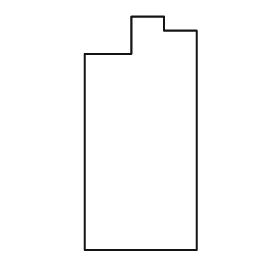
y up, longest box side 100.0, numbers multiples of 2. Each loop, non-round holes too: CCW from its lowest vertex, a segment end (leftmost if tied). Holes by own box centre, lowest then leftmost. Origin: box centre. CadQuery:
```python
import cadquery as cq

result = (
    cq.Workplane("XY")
    .moveTo(-24.0, -50.0)
    .lineTo(24.0, -50.0)
    .lineTo(24.0, 44.0)
    .lineTo(10.0, 44.0)
    .lineTo(10.0, 50.0)
    .lineTo(-4.0, 50.0)
    .lineTo(-4.0, 34.0)
    .lineTo(-24.0, 34.0)
    .close()
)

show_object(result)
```